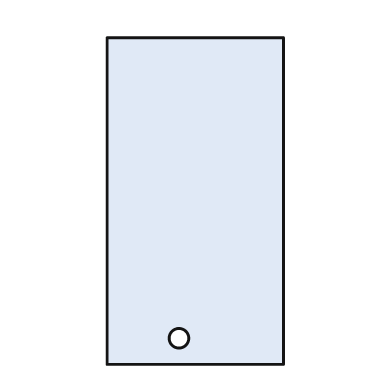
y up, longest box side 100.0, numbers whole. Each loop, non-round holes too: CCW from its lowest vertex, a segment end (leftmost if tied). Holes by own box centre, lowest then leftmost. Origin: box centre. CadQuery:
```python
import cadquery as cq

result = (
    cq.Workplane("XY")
    .moveTo(-27.0, -50.0)
    .lineTo(27.0, -50.0)
    .lineTo(27.0, 50.0)
    .lineTo(-27.0, 50.0)
    .close()
    .moveTo(-5.0, -42.0)
    .circle(3.0)
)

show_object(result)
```